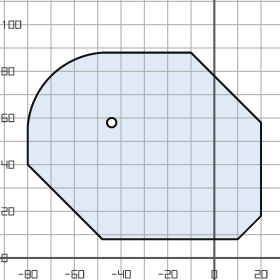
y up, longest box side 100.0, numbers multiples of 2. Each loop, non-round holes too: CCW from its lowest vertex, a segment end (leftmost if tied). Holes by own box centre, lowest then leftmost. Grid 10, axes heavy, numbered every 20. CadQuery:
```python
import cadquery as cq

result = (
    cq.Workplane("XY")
    .moveTo(-48.0, 8.0)
    .lineTo(10.0, 8.0)
    .lineTo(20.0, 18.0)
    .lineTo(20.0, 58.0)
    .lineTo(-10.0, 88.0)
    .lineTo(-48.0, 88.0)
    .threePointArc((-70.0, 78.0), (-80.0, 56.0))
    .lineTo(-80.0, 40.0)
    .close()
    .moveTo(-44.0, 58.0)
    .circle(2.0)
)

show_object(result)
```